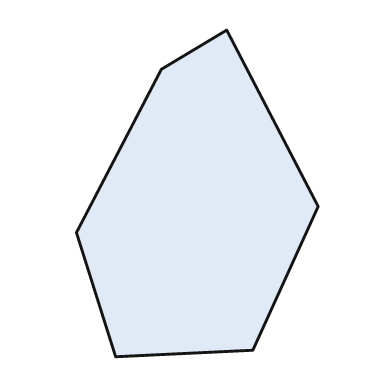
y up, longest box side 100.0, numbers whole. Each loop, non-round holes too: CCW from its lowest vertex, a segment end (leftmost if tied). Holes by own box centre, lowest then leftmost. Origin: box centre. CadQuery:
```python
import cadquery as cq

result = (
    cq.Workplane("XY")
    .moveTo(-25.0, -50.0)
    .lineTo(17.0, -48.0)
    .lineTo(37.0, -4.0)
    .lineTo(9.0, 50.0)
    .lineTo(-11.0, 38.0)
    .lineTo(-37.0, -12.0)
    .close()
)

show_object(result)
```